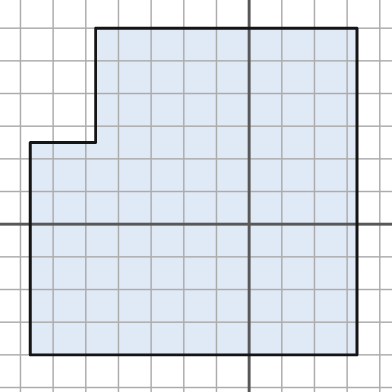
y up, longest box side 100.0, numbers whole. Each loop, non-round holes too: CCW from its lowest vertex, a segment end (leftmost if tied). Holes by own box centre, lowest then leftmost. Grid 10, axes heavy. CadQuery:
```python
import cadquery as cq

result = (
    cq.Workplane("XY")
    .moveTo(-67.0, -40.0)
    .lineTo(33.0, -40.0)
    .lineTo(33.0, 60.0)
    .lineTo(-47.0, 60.0)
    .lineTo(-47.0, 25.0)
    .lineTo(-67.0, 25.0)
    .close()
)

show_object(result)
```